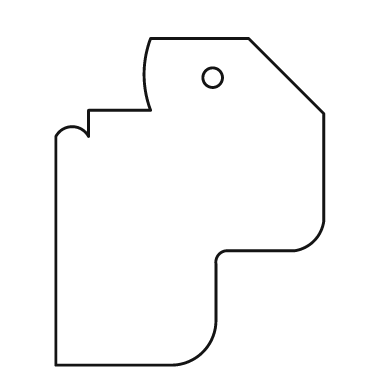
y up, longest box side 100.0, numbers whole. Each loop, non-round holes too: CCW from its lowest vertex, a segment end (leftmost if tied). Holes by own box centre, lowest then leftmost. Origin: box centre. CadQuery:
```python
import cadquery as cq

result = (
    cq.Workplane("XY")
    .moveTo(-41.0, -50.0)
    .lineTo(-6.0, -50.0)
    .threePointArc((4.0, -46.0), (8.0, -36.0))
    .lineTo(8.0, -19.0)
    .threePointArc((9.0, -16.0), (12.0, -15.0))
    .lineTo(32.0, -15.0)
    .threePointArc((38.0, -12.0), (41.0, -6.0))
    .lineTo(41.0, 27.0)
    .lineTo(18.0, 50.0)
    .lineTo(-12.0, 50.0)
    .threePointArc((-14.0, 39.0), (-12.0, 28.0))
    .lineTo(-31.0, 28.0)
    .lineTo(-31.0, 20.0)
    .threePointArc((-36.0, 23.0), (-41.0, 20.0))
    .close()
    .moveTo(7.0, 38.0)
    .circle(3.0)
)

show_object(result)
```